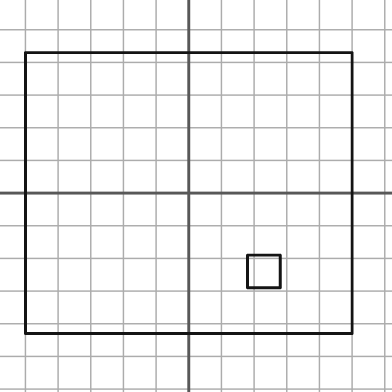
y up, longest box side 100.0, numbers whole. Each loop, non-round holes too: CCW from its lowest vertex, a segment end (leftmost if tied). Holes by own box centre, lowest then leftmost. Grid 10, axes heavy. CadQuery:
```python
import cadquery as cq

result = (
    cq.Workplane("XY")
    .moveTo(-50.0, -43.0)
    .lineTo(50.0, -43.0)
    .lineTo(50.0, 43.0)
    .lineTo(-50.0, 43.0)
    .close()
    .moveTo(18.0, -29.0)
    .lineTo(28.0, -29.0)
    .lineTo(28.0, -19.0)
    .lineTo(18.0, -19.0)
    .close()
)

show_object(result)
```